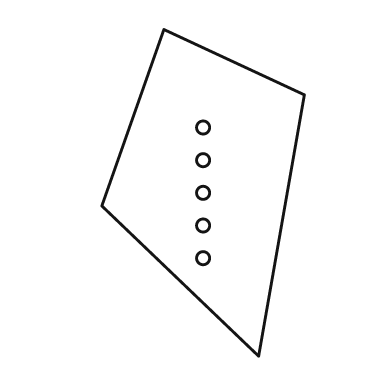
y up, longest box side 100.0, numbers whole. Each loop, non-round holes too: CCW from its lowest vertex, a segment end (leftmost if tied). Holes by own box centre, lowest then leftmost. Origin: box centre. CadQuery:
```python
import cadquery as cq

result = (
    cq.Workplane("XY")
    .moveTo(17.0, -50.0)
    .lineTo(31.0, 30.0)
    .lineTo(-12.0, 50.0)
    .lineTo(-31.0, -4.0)
    .close()
    .moveTo(0.0, -20.0)
    .circle(2.0)
    .moveTo(0.0, -10.0)
    .circle(2.0)
    .moveTo(0.0, 0.0)
    .circle(2.0)
    .moveTo(0.0, 10.0)
    .circle(2.0)
    .moveTo(0.0, 20.0)
    .circle(2.0)
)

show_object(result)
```